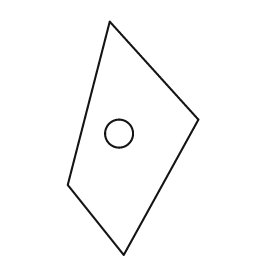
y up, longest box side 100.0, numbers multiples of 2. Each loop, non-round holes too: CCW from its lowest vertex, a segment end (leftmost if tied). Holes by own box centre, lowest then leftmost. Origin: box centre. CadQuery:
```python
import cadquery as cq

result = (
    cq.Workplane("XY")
    .moveTo(-4.0, -50.0)
    .lineTo(28.0, 8.0)
    .lineTo(-10.0, 50.0)
    .lineTo(-28.0, -20.0)
    .close()
    .moveTo(-6.0, 2.0)
    .circle(6.0)
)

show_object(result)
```